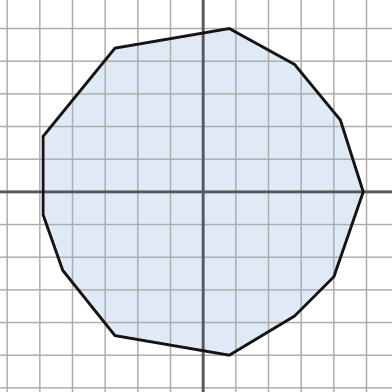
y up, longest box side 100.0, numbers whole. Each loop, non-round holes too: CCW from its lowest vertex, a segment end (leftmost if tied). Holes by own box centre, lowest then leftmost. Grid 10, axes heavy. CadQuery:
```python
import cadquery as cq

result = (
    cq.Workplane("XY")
    .moveTo(8.0, -50.0)
    .lineTo(28.0, -38.0)
    .lineTo(40.0, -26.0)
    .lineTo(49.0, 0.0)
    .lineTo(42.0, 22.0)
    .lineTo(28.0, 39.0)
    .lineTo(8.0, 50.0)
    .lineTo(-27.0, 44.0)
    .lineTo(-49.0, 17.0)
    .lineTo(-49.0, -7.0)
    .lineTo(-43.0, -24.0)
    .lineTo(-27.0, -44.0)
    .close()
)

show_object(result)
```